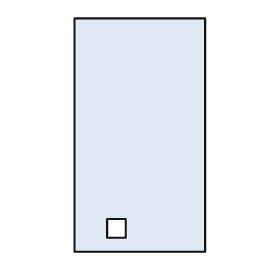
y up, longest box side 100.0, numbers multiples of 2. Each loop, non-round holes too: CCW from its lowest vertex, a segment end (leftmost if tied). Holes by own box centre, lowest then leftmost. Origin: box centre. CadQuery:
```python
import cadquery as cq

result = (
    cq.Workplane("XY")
    .moveTo(-28.0, -50.0)
    .lineTo(28.0, -50.0)
    .lineTo(28.0, 50.0)
    .lineTo(-28.0, 50.0)
    .close()
    .moveTo(-14.0, -44.0)
    .lineTo(-6.0, -44.0)
    .lineTo(-6.0, -36.0)
    .lineTo(-14.0, -36.0)
    .close()
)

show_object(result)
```